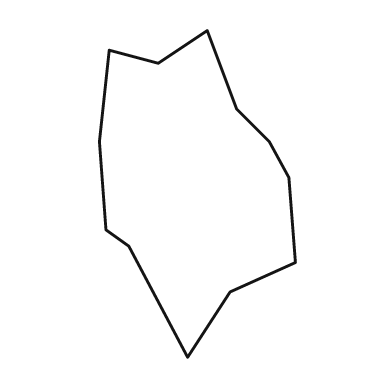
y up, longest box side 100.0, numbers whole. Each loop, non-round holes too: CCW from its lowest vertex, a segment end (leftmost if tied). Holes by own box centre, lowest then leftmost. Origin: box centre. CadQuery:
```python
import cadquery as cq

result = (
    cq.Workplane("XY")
    .moveTo(-3.0, -50.0)
    .lineTo(10.0, -30.0)
    .lineTo(30.0, -21.0)
    .lineTo(28.0, 5.0)
    .lineTo(22.0, 16.0)
    .lineTo(12.0, 26.0)
    .lineTo(3.0, 50.0)
    .lineTo(-12.0, 40.0)
    .lineTo(-27.0, 44.0)
    .lineTo(-30.0, 16.0)
    .lineTo(-28.0, -11.0)
    .lineTo(-21.0, -16.0)
    .close()
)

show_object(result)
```